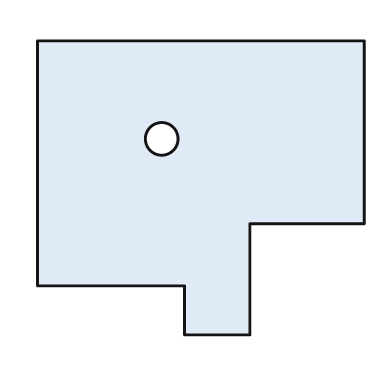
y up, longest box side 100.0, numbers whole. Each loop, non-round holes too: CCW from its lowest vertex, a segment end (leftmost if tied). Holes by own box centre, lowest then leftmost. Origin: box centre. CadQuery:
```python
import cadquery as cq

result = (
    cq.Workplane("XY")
    .moveTo(-5.0, -45.0)
    .lineTo(15.0, -45.0)
    .lineTo(15.0, -11.0)
    .lineTo(50.0, -11.0)
    .lineTo(50.0, 45.0)
    .lineTo(-50.0, 45.0)
    .lineTo(-50.0, -30.0)
    .lineTo(-5.0, -30.0)
    .close()
    .moveTo(-12.0, 15.0)
    .circle(5.0)
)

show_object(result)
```